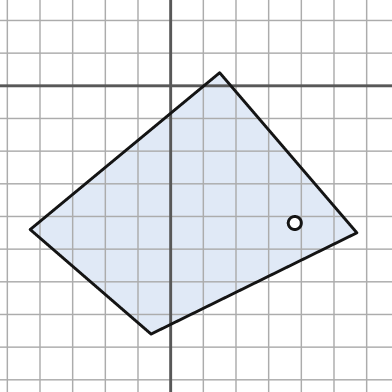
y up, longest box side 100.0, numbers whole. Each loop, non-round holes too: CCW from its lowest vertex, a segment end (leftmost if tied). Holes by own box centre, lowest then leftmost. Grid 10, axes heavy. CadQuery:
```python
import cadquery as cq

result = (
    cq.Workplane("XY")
    .moveTo(-6.0, -76.0)
    .lineTo(57.0, -45.0)
    .lineTo(15.0, 4.0)
    .lineTo(-43.0, -44.0)
    .close()
    .moveTo(38.0, -42.0)
    .circle(2.0)
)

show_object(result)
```